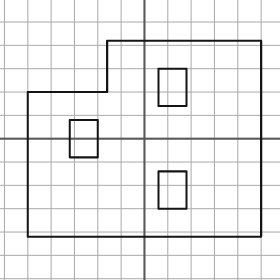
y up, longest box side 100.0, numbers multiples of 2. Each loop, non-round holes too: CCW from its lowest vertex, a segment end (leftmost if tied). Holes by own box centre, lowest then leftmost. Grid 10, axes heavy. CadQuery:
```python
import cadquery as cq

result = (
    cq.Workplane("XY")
    .moveTo(-50.0, -42.0)
    .lineTo(50.0, -42.0)
    .lineTo(50.0, 42.0)
    .lineTo(-16.0, 42.0)
    .lineTo(-16.0, 20.0)
    .lineTo(-50.0, 20.0)
    .close()
    .moveTo(6.0, -30.0)
    .lineTo(18.0, -30.0)
    .lineTo(18.0, -14.0)
    .lineTo(6.0, -14.0)
    .close()
    .moveTo(-32.0, -8.0)
    .lineTo(-20.0, -8.0)
    .lineTo(-20.0, 8.0)
    .lineTo(-32.0, 8.0)
    .close()
    .moveTo(6.0, 14.0)
    .lineTo(18.0, 14.0)
    .lineTo(18.0, 30.0)
    .lineTo(6.0, 30.0)
    .close()
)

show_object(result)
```